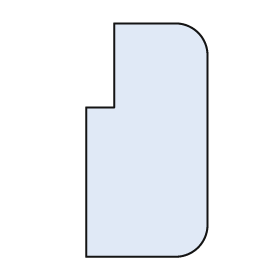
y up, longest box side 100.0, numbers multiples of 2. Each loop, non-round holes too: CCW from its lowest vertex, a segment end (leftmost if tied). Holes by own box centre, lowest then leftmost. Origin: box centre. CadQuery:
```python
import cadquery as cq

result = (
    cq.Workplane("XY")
    .moveTo(-26.0, -50.0)
    .lineTo(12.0, -50.0)
    .threePointArc((22.0, -46.0), (26.0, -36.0))
    .lineTo(26.0, 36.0)
    .threePointArc((22.0, 46.0), (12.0, 50.0))
    .lineTo(-14.0, 50.0)
    .lineTo(-14.0, 14.0)
    .lineTo(-26.0, 14.0)
    .close()
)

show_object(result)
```